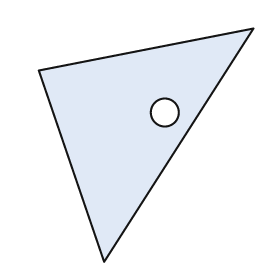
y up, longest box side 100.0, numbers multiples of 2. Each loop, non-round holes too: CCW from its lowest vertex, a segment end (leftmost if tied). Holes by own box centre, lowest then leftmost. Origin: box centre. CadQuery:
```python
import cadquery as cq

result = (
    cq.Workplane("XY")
    .moveTo(-18.0, -50.0)
    .lineTo(46.0, 50.0)
    .lineTo(-46.0, 32.0)
    .close()
    .moveTo(8.0, 14.0)
    .circle(6.0)
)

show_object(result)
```